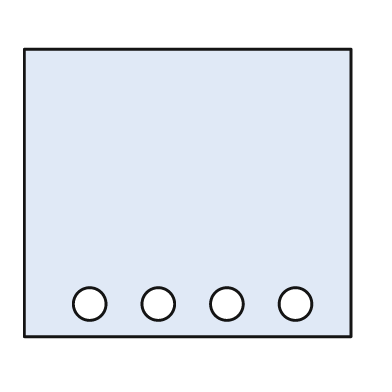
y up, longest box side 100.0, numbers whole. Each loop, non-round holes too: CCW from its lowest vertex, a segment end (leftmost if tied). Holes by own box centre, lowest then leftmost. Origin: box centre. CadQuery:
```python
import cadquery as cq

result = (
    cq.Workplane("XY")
    .moveTo(-50.0, -44.0)
    .lineTo(50.0, -44.0)
    .lineTo(50.0, 44.0)
    .lineTo(-50.0, 44.0)
    .close()
    .moveTo(-30.0, -34.0)
    .circle(5.0)
    .moveTo(-9.0, -34.0)
    .circle(5.0)
    .moveTo(12.0, -34.0)
    .circle(5.0)
    .moveTo(33.0, -34.0)
    .circle(5.0)
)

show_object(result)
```